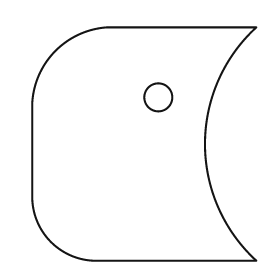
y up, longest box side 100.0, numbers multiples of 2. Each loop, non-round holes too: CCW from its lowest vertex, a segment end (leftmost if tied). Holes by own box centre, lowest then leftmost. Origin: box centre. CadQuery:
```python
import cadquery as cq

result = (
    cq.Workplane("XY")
    .moveTo(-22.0, -50.0)
    .lineTo(48.0, -50.0)
    .threePointArc((26.0, 0.0), (48.0, 50.0))
    .lineTo(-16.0, 50.0)
    .threePointArc((-38.0, 40.0), (-48.0, 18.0))
    .lineTo(-48.0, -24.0)
    .threePointArc((-40.0, -42.0), (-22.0, -50.0))
    .close()
    .moveTo(6.0, 20.0)
    .circle(6.0)
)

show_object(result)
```